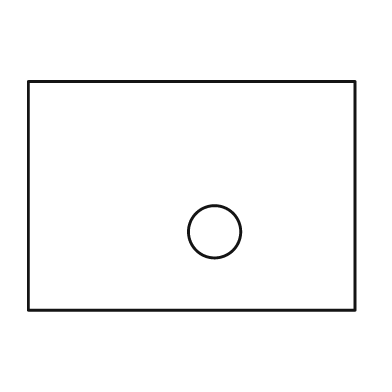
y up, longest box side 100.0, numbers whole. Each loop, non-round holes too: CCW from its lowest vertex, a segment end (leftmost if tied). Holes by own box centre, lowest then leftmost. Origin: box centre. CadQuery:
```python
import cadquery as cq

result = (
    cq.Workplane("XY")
    .moveTo(-50.0, -35.0)
    .lineTo(50.0, -35.0)
    .lineTo(50.0, 35.0)
    .lineTo(-50.0, 35.0)
    .close()
    .moveTo(7.0, -11.0)
    .circle(8.0)
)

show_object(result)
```